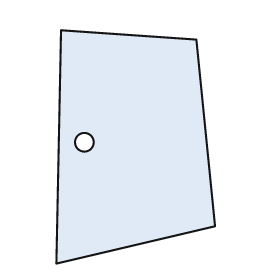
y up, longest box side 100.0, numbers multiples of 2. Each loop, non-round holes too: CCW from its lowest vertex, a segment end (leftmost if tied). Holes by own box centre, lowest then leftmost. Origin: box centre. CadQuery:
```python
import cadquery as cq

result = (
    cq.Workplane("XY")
    .moveTo(-34.0, -50.0)
    .lineTo(34.0, -34.0)
    .lineTo(26.0, 46.0)
    .lineTo(-32.0, 50.0)
    .close()
    .moveTo(-22.0, 2.0)
    .circle(4.0)
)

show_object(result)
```